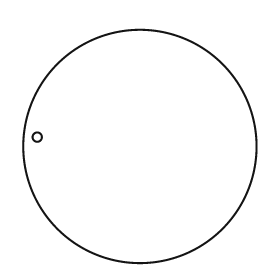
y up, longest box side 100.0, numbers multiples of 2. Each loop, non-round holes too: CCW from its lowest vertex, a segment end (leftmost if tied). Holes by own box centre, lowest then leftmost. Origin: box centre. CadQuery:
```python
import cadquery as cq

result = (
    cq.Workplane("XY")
    .moveTo(0.0, 0.0)
    .circle(50.0)
    .moveTo(-44.0, 4.0)
    .circle(2.0)
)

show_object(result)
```